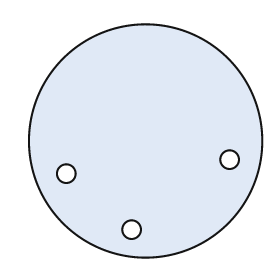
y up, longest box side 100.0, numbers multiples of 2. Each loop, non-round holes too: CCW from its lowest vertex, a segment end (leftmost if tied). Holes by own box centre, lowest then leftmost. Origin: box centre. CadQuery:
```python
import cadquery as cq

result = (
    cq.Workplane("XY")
    .moveTo(0.0, 0.0)
    .circle(50.0)
    .moveTo(-6.0, -38.0)
    .circle(4.0)
    .moveTo(-34.0, -14.0)
    .circle(4.0)
    .moveTo(36.0, -8.0)
    .circle(4.0)
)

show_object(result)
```